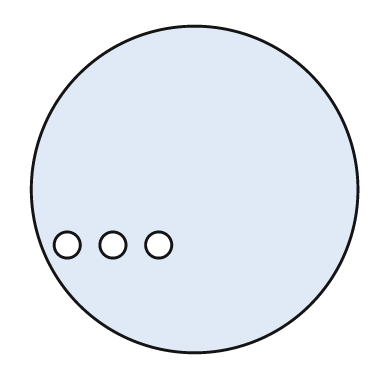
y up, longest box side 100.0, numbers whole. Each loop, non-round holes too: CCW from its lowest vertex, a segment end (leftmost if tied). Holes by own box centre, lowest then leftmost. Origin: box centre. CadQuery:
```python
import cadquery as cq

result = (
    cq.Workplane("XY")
    .moveTo(0.0, 0.0)
    .circle(50.0)
    .moveTo(-39.0, -17.0)
    .circle(4.0)
    .moveTo(-25.0, -17.0)
    .circle(4.0)
    .moveTo(-11.0, -17.0)
    .circle(4.0)
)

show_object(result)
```